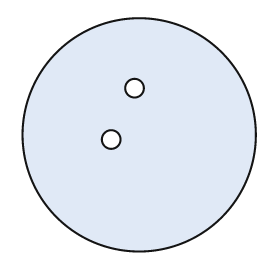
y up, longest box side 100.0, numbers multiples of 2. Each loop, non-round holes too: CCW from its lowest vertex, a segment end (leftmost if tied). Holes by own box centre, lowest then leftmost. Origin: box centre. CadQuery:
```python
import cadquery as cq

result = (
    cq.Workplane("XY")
    .moveTo(0.0, 0.0)
    .circle(50.0)
    .moveTo(-12.0, -2.0)
    .circle(4.0)
    .moveTo(-2.0, 20.0)
    .circle(4.0)
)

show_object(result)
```